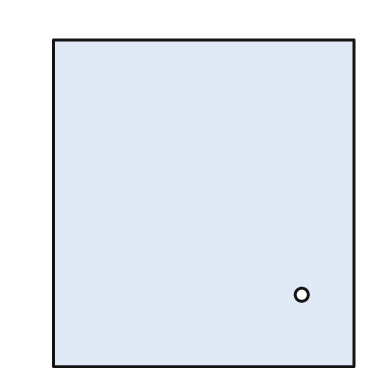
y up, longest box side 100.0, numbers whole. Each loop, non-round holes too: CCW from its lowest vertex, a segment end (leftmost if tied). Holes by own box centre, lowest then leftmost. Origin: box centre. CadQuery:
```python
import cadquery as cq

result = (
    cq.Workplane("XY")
    .moveTo(-46.0, -50.0)
    .lineTo(46.0, -50.0)
    .lineTo(46.0, 50.0)
    .lineTo(-46.0, 50.0)
    .close()
    .moveTo(30.0, -28.0)
    .circle(2.0)
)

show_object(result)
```